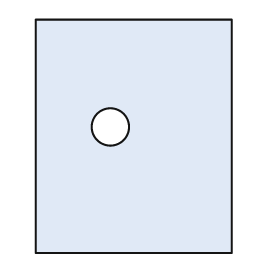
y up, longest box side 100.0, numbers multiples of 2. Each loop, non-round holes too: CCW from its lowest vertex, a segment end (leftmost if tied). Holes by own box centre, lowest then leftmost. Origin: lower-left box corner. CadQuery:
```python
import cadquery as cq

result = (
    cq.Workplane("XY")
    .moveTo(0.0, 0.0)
    .lineTo(84.0, 0.0)
    .lineTo(84.0, 100.0)
    .lineTo(0.0, 100.0)
    .close()
    .moveTo(32.0, 54.0)
    .circle(8.0)
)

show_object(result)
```